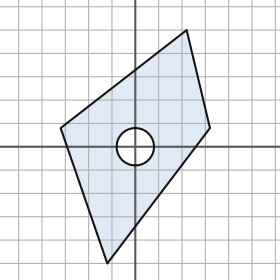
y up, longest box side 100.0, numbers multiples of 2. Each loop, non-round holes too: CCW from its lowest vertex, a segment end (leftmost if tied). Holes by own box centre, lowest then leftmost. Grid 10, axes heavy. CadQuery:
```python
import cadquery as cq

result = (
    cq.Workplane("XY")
    .moveTo(-12.0, -50.0)
    .lineTo(32.0, 8.0)
    .lineTo(22.0, 50.0)
    .lineTo(-32.0, 8.0)
    .close()
    .moveTo(0.0, 0.0)
    .circle(8.0)
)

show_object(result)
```